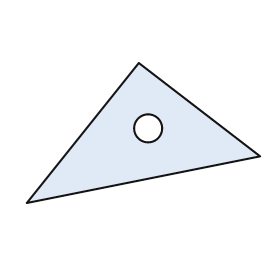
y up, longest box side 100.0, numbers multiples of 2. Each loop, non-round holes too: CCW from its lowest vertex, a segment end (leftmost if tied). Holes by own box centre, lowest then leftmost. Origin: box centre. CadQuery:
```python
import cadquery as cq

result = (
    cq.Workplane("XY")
    .moveTo(-50.0, -30.0)
    .lineTo(50.0, -10.0)
    .lineTo(-2.0, 30.0)
    .close()
    .moveTo(2.0, 2.0)
    .circle(6.0)
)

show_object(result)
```